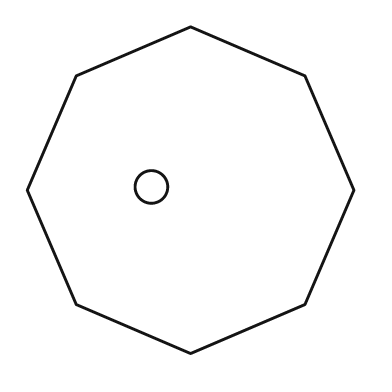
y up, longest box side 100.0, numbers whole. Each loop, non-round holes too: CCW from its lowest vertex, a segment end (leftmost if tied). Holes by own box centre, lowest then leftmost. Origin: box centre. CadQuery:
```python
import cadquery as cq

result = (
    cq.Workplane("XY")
    .moveTo(0.0, -50.0)
    .lineTo(35.0, -35.0)
    .lineTo(50.0, 0.0)
    .lineTo(35.0, 35.0)
    .lineTo(0.0, 50.0)
    .lineTo(-35.0, 35.0)
    .lineTo(-50.0, 0.0)
    .lineTo(-35.0, -35.0)
    .close()
    .moveTo(-12.0, 1.0)
    .circle(5.0)
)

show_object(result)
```